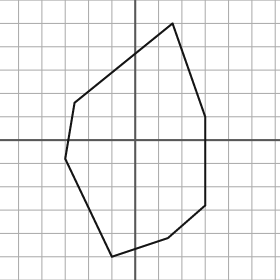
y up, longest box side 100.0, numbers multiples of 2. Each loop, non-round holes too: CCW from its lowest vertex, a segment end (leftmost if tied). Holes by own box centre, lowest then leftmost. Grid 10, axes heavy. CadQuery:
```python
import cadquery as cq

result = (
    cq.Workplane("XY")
    .moveTo(-10.0, -50.0)
    .lineTo(14.0, -42.0)
    .lineTo(30.0, -28.0)
    .lineTo(30.0, 10.0)
    .lineTo(16.0, 50.0)
    .lineTo(-26.0, 16.0)
    .lineTo(-30.0, -8.0)
    .close()
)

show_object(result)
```